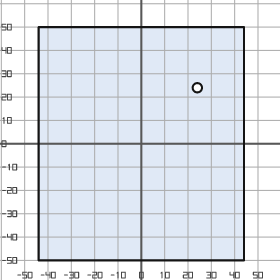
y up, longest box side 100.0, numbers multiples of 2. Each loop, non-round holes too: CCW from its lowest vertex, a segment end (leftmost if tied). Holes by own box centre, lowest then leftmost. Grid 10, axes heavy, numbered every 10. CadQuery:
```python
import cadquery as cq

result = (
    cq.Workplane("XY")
    .moveTo(-44.0, -50.0)
    .lineTo(44.0, -50.0)
    .lineTo(44.0, 50.0)
    .lineTo(-44.0, 50.0)
    .close()
    .moveTo(24.0, 24.0)
    .circle(2.0)
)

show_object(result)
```